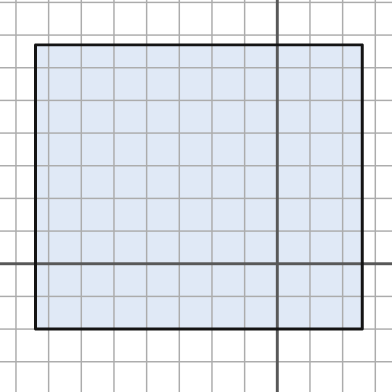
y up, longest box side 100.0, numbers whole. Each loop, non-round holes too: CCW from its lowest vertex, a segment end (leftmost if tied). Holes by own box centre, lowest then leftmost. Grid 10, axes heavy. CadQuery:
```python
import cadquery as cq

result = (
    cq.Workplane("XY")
    .moveTo(-74.0, -20.0)
    .lineTo(26.0, -20.0)
    .lineTo(26.0, 67.0)
    .lineTo(-74.0, 67.0)
    .close()
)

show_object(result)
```